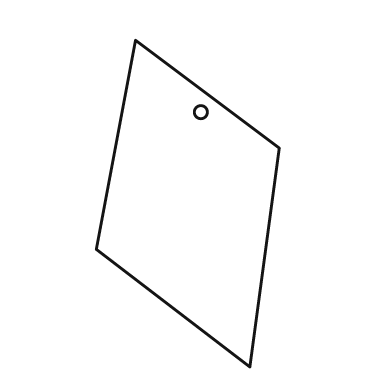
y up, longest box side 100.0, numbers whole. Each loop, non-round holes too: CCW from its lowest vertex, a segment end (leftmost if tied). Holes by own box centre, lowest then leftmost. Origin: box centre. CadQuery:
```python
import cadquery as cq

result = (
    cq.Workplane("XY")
    .moveTo(19.0, -50.0)
    .lineTo(28.0, 17.0)
    .lineTo(-16.0, 50.0)
    .lineTo(-28.0, -14.0)
    .close()
    .moveTo(4.0, 28.0)
    .circle(2.0)
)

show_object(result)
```